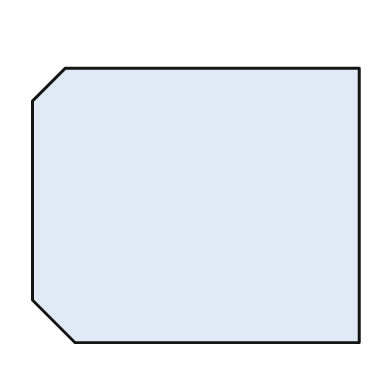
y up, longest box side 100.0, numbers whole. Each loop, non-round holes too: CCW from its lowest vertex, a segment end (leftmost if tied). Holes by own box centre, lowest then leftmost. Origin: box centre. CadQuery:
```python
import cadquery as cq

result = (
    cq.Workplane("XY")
    .moveTo(-37.0, -42.0)
    .lineTo(50.0, -42.0)
    .lineTo(50.0, 42.0)
    .lineTo(-40.0, 42.0)
    .lineTo(-50.0, 32.0)
    .lineTo(-50.0, -29.0)
    .close()
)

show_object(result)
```